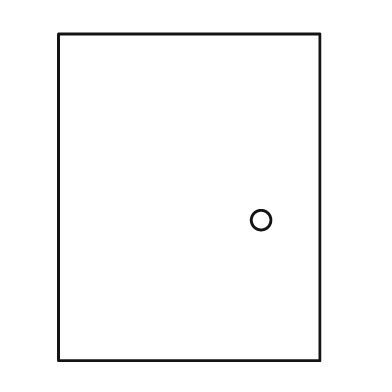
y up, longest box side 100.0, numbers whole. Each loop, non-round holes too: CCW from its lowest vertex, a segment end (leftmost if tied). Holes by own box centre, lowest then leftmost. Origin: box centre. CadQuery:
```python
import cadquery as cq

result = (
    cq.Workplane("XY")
    .moveTo(-40.0, -50.0)
    .lineTo(40.0, -50.0)
    .lineTo(40.0, 50.0)
    .lineTo(-40.0, 50.0)
    .close()
    .moveTo(22.0, -7.0)
    .circle(3.0)
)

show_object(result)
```